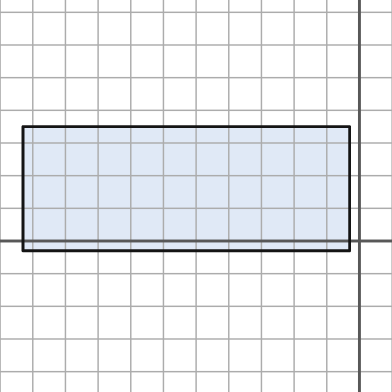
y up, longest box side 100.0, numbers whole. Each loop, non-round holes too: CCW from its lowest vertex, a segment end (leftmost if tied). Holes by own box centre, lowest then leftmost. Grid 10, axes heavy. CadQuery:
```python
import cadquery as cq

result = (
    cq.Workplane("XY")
    .moveTo(-103.0, -3.0)
    .lineTo(-3.0, -3.0)
    .lineTo(-3.0, 35.0)
    .lineTo(-103.0, 35.0)
    .close()
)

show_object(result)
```